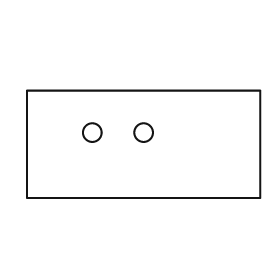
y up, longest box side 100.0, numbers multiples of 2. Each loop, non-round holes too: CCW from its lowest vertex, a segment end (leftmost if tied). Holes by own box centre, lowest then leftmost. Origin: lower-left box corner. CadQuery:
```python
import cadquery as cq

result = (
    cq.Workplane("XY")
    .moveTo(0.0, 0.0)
    .lineTo(100.0, 0.0)
    .lineTo(100.0, 46.0)
    .lineTo(0.0, 46.0)
    .close()
    .moveTo(28.0, 28.0)
    .circle(4.0)
    .moveTo(50.0, 28.0)
    .circle(4.0)
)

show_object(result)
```